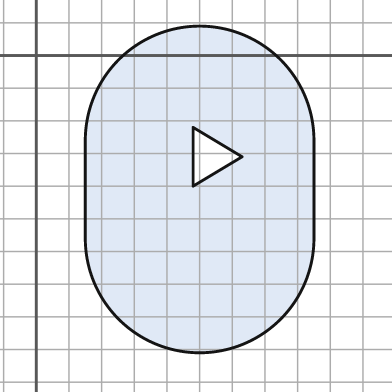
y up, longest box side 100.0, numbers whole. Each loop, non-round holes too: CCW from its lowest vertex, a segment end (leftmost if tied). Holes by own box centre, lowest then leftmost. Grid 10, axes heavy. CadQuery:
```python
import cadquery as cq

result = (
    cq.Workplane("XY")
    .moveTo(15.0, -56.0)
    .threePointArc((50.0, -91.0), (85.0, -56.0))
    .lineTo(85.0, -26.0)
    .threePointArc((50.0, 9.0), (15.0, -26.0))
    .close()
    .moveTo(48.0, -40.0)
    .lineTo(63.0, -31.0)
    .lineTo(48.0, -22.0)
    .close()
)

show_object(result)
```